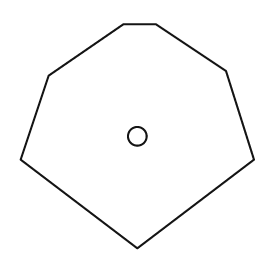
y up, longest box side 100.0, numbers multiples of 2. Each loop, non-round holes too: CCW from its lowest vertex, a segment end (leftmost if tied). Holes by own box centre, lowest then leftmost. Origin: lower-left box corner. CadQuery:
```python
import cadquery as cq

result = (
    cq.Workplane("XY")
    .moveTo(50.0, 0.0)
    .lineTo(100.0, 38.0)
    .lineTo(88.0, 76.0)
    .lineTo(58.0, 96.0)
    .lineTo(44.0, 96.0)
    .lineTo(12.0, 74.0)
    .lineTo(0.0, 38.0)
    .close()
    .moveTo(50.0, 48.0)
    .circle(4.0)
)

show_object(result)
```